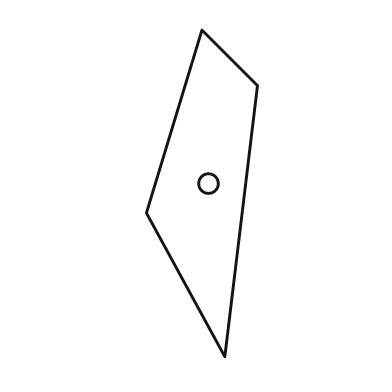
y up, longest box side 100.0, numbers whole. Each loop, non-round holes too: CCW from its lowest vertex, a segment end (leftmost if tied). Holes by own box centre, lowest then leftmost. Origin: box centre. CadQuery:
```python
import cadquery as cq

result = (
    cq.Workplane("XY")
    .moveTo(7.0, -50.0)
    .lineTo(17.0, 33.0)
    .lineTo(0.0, 50.0)
    .lineTo(-17.0, -6.0)
    .close()
    .moveTo(2.0, 3.0)
    .circle(3.0)
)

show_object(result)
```